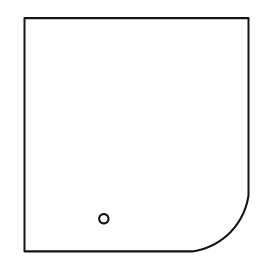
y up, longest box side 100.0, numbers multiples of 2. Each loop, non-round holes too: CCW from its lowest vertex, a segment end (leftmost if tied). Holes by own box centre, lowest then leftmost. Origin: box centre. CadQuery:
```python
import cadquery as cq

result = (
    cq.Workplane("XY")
    .moveTo(-48.0, -50.0)
    .lineTo(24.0, -50.0)
    .threePointArc((40.0, -42.0), (48.0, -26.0))
    .lineTo(48.0, 50.0)
    .lineTo(-48.0, 50.0)
    .close()
    .moveTo(-14.0, -36.0)
    .circle(2.0)
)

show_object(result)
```